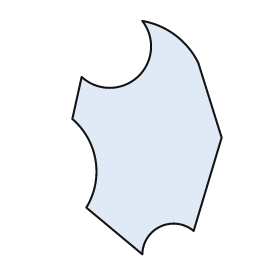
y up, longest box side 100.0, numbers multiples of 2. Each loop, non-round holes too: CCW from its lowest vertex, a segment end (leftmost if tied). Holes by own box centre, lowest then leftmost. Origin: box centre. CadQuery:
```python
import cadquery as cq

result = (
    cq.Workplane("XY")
    .moveTo(-2.0, -50.0)
    .threePointArc((6.0, -38.0), (20.0, -40.0))
    .lineTo(32.0, 0.0)
    .lineTo(22.0, 32.0)
    .threePointArc((12.0, 44.0), (-2.0, 50.0))
    .threePointArc((-4.0, 26.0), (-28.0, 26.0))
    .lineTo(-32.0, 8.0)
    .threePointArc((-22.0, -10.0), (-26.0, -30.0))
    .close()
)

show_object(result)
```